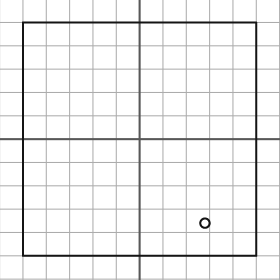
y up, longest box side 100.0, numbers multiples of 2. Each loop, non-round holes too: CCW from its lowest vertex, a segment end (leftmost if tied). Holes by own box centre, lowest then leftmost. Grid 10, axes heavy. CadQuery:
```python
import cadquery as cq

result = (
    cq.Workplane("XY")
    .moveTo(-50.0, -50.0)
    .lineTo(50.0, -50.0)
    .lineTo(50.0, 50.0)
    .lineTo(-50.0, 50.0)
    .close()
    .moveTo(28.0, -36.0)
    .circle(2.0)
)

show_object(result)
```